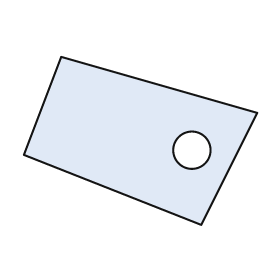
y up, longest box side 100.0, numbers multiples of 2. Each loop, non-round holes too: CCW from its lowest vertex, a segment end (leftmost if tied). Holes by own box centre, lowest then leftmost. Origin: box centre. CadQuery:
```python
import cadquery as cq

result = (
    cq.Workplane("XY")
    .moveTo(26.0, -36.0)
    .lineTo(50.0, 12.0)
    .lineTo(-34.0, 36.0)
    .lineTo(-50.0, -6.0)
    .close()
    .moveTo(22.0, -4.0)
    .circle(8.0)
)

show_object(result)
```